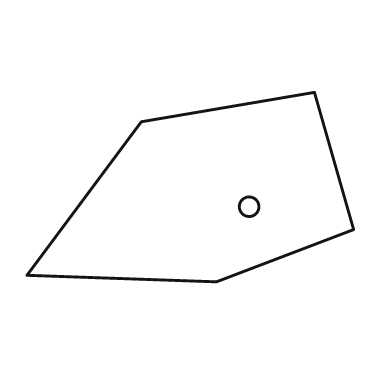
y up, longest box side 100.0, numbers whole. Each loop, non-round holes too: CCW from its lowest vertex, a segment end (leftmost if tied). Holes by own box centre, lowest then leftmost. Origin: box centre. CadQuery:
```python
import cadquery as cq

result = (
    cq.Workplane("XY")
    .moveTo(8.0, -29.0)
    .lineTo(50.0, -13.0)
    .lineTo(38.0, 29.0)
    .lineTo(-15.0, 20.0)
    .lineTo(-50.0, -27.0)
    .close()
    .moveTo(18.0, -6.0)
    .circle(3.0)
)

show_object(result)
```